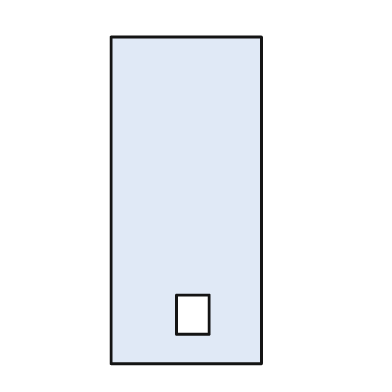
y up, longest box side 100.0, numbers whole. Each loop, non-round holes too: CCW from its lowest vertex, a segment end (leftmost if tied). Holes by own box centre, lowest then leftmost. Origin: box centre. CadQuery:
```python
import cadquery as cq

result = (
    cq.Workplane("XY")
    .moveTo(-23.0, -50.0)
    .lineTo(23.0, -50.0)
    .lineTo(23.0, 50.0)
    .lineTo(-23.0, 50.0)
    .close()
    .moveTo(-3.0, -41.0)
    .lineTo(7.0, -41.0)
    .lineTo(7.0, -29.0)
    .lineTo(-3.0, -29.0)
    .close()
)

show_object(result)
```